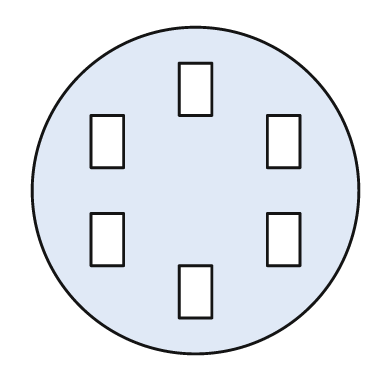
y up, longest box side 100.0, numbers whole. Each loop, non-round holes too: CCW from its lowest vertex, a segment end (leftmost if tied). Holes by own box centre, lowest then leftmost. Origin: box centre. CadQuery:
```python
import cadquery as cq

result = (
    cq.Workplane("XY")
    .moveTo(0.0, 0.0)
    .circle(50.0)
    .moveTo(-5.0, -39.0)
    .lineTo(5.0, -39.0)
    .lineTo(5.0, -23.0)
    .lineTo(-5.0, -23.0)
    .close()
    .moveTo(-32.0, -23.0)
    .lineTo(-22.0, -23.0)
    .lineTo(-22.0, -7.0)
    .lineTo(-32.0, -7.0)
    .close()
    .moveTo(22.0, -23.0)
    .lineTo(32.0, -23.0)
    .lineTo(32.0, -7.0)
    .lineTo(22.0, -7.0)
    .close()
    .moveTo(-32.0, 7.0)
    .lineTo(-22.0, 7.0)
    .lineTo(-22.0, 23.0)
    .lineTo(-32.0, 23.0)
    .close()
    .moveTo(22.0, 7.0)
    .lineTo(32.0, 7.0)
    .lineTo(32.0, 23.0)
    .lineTo(22.0, 23.0)
    .close()
    .moveTo(-5.0, 23.0)
    .lineTo(5.0, 23.0)
    .lineTo(5.0, 39.0)
    .lineTo(-5.0, 39.0)
    .close()
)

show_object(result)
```